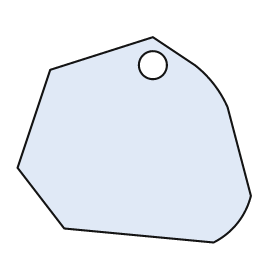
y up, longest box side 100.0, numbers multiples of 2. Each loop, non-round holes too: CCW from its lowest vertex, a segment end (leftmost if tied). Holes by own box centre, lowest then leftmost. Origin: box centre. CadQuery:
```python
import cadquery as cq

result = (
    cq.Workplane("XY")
    .moveTo(34.0, -44.0)
    .threePointArc((44.0, -36.0), (50.0, -24.0))
    .lineTo(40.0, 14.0)
    .threePointArc((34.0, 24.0), (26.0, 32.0))
    .lineTo(8.0, 44.0)
    .lineTo(-36.0, 30.0)
    .lineTo(-50.0, -12.0)
    .lineTo(-30.0, -38.0)
    .close()
    .moveTo(8.0, 32.0)
    .circle(6.0)
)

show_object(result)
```